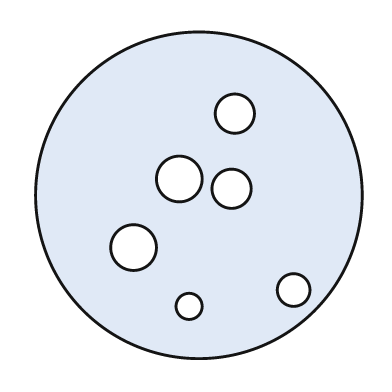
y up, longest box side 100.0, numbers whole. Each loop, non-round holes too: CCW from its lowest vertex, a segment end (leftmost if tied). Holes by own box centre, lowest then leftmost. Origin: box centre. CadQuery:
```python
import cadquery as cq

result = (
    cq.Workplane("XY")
    .moveTo(0.0, 0.0)
    .circle(50.0)
    .moveTo(-3.0, -34.0)
    .circle(4.0)
    .moveTo(29.0, -29.0)
    .circle(5.0)
    .moveTo(-20.0, -16.0)
    .circle(7.0)
    .moveTo(10.0, 2.0)
    .circle(6.0)
    .moveTo(-6.0, 5.0)
    .circle(7.0)
    .moveTo(11.0, 25.0)
    .circle(6.0)
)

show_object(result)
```